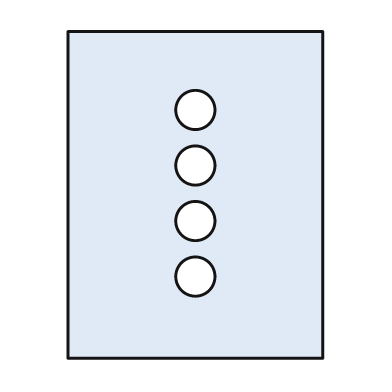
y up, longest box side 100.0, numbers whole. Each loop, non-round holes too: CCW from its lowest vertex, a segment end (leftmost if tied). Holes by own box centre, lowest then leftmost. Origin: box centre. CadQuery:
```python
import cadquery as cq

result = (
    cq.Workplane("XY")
    .moveTo(-39.0, -50.0)
    .lineTo(39.0, -50.0)
    .lineTo(39.0, 50.0)
    .lineTo(-39.0, 50.0)
    .close()
    .moveTo(0.0, -25.0)
    .circle(6.0)
    .moveTo(0.0, -8.0)
    .circle(6.0)
    .moveTo(0.0, 9.0)
    .circle(6.0)
    .moveTo(0.0, 26.0)
    .circle(6.0)
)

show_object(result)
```